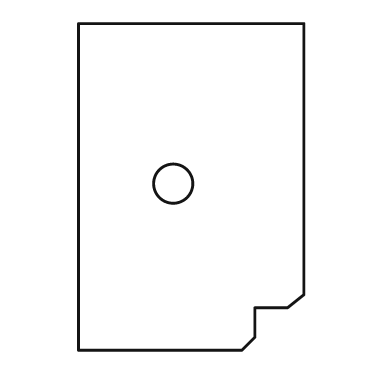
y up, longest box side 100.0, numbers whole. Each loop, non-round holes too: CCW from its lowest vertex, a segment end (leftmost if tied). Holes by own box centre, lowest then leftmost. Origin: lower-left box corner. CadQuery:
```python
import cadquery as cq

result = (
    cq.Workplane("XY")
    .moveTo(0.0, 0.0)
    .lineTo(50.0, 0.0)
    .lineTo(54.0, 4.0)
    .lineTo(54.0, 13.0)
    .lineTo(64.0, 13.0)
    .lineTo(69.0, 17.0)
    .lineTo(69.0, 100.0)
    .lineTo(0.0, 100.0)
    .close()
    .moveTo(29.0, 51.0)
    .circle(6.0)
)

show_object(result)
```